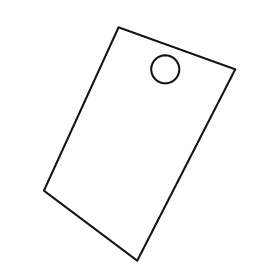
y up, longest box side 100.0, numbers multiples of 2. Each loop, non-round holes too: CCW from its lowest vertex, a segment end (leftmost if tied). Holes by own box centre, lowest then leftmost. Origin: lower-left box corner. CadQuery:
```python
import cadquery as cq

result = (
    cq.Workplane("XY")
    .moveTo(40.0, 0.0)
    .lineTo(82.0, 82.0)
    .lineTo(32.0, 100.0)
    .lineTo(0.0, 30.0)
    .close()
    .moveTo(52.0, 82.0)
    .circle(6.0)
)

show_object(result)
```